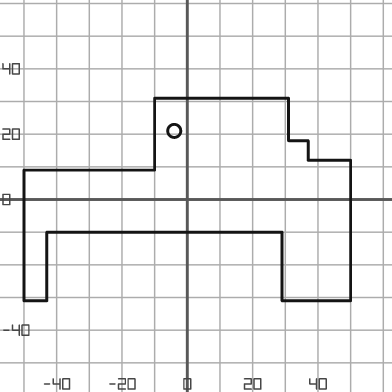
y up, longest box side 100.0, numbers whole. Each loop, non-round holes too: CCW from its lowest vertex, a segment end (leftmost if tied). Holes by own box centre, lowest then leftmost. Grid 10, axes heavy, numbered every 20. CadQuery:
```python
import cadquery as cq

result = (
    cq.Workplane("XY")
    .moveTo(-50.0, -31.0)
    .lineTo(-43.0, -31.0)
    .lineTo(-43.0, -10.0)
    .lineTo(29.0, -10.0)
    .lineTo(29.0, -31.0)
    .lineTo(50.0, -31.0)
    .lineTo(50.0, 12.0)
    .lineTo(37.0, 12.0)
    .lineTo(37.0, 18.0)
    .lineTo(31.0, 18.0)
    .lineTo(31.0, 31.0)
    .lineTo(-10.0, 31.0)
    .lineTo(-10.0, 9.0)
    .lineTo(-50.0, 9.0)
    .close()
    .moveTo(-4.0, 21.0)
    .circle(2.0)
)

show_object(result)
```